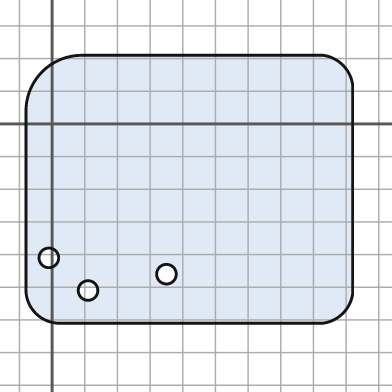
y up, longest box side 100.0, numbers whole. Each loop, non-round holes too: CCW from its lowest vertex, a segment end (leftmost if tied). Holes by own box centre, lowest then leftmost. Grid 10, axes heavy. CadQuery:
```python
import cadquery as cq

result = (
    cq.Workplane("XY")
    .moveTo(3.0, -61.0)
    .lineTo(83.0, -61.0)
    .threePointArc((89.0, -58.0), (92.0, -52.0))
    .lineTo(92.0, 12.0)
    .threePointArc((89.0, 18.0), (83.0, 21.0))
    .lineTo(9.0, 21.0)
    .threePointArc((-3.0, 16.0), (-8.0, 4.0))
    .lineTo(-8.0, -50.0)
    .threePointArc((-5.0, -58.0), (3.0, -61.0))
    .close()
    .moveTo(11.0, -51.0)
    .circle(3.0)
    .moveTo(35.0, -46.0)
    .circle(3.0)
    .moveTo(-1.0, -41.0)
    .circle(3.0)
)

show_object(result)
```